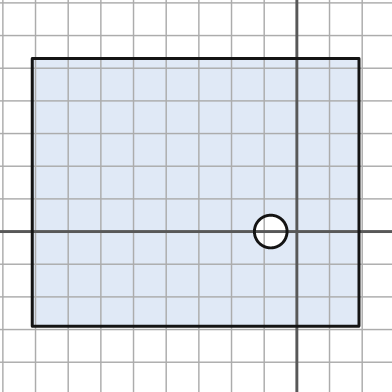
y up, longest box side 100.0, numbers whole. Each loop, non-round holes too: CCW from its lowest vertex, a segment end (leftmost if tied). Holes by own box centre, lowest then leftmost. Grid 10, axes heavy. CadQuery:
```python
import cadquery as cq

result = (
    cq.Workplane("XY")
    .moveTo(-81.0, -29.0)
    .lineTo(19.0, -29.0)
    .lineTo(19.0, 53.0)
    .lineTo(-81.0, 53.0)
    .close()
    .moveTo(-8.0, 0.0)
    .circle(5.0)
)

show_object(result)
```